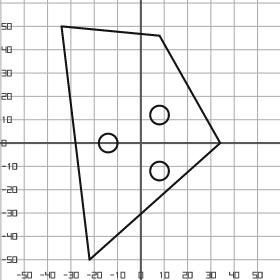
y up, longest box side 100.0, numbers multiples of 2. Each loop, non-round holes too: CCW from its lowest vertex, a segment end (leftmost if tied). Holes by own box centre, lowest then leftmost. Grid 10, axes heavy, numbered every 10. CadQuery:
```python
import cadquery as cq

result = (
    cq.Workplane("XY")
    .moveTo(-22.0, -50.0)
    .lineTo(34.0, 0.0)
    .lineTo(8.0, 46.0)
    .lineTo(-34.0, 50.0)
    .close()
    .moveTo(8.0, -12.0)
    .circle(4.0)
    .moveTo(-14.0, 0.0)
    .circle(4.0)
    .moveTo(8.0, 12.0)
    .circle(4.0)
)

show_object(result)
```